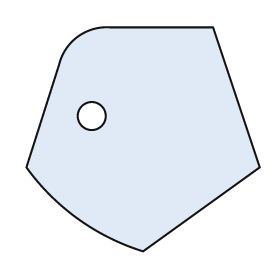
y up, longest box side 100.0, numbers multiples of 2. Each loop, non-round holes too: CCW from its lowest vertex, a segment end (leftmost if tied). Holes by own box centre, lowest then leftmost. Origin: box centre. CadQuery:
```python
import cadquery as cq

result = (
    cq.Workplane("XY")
    .moveTo(0.0, -48.0)
    .lineTo(50.0, -12.0)
    .lineTo(30.0, 48.0)
    .lineTo(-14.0, 48.0)
    .threePointArc((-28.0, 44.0), (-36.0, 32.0))
    .lineTo(-50.0, -12.0)
    .threePointArc((-28.0, -34.0), (0.0, -48.0))
    .close()
    .moveTo(-22.0, 10.0)
    .circle(6.0)
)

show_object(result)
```